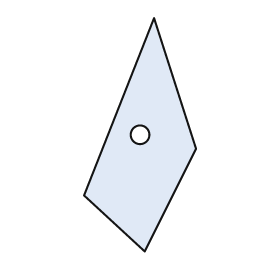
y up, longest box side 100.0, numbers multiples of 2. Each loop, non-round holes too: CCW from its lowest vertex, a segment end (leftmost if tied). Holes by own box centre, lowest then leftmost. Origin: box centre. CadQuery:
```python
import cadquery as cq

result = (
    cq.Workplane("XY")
    .moveTo(2.0, -50.0)
    .lineTo(24.0, -6.0)
    .lineTo(6.0, 50.0)
    .lineTo(-24.0, -26.0)
    .close()
    .moveTo(0.0, 0.0)
    .circle(4.0)
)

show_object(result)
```